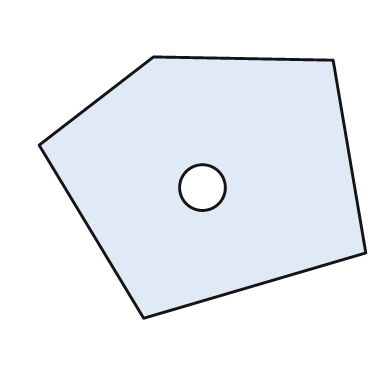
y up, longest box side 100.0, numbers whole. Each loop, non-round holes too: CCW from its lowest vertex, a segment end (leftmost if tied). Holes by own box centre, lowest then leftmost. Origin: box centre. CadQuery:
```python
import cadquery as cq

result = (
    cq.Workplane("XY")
    .moveTo(-18.0, -40.0)
    .lineTo(50.0, -20.0)
    .lineTo(40.0, 39.0)
    .lineTo(-15.0, 40.0)
    .lineTo(-50.0, 13.0)
    .close()
    .moveTo(0.0, 0.0)
    .circle(7.0)
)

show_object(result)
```